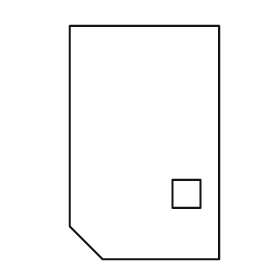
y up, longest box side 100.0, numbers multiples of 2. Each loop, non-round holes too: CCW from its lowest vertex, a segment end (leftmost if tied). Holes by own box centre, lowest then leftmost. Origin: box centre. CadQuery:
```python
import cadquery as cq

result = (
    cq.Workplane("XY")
    .moveTo(-18.0, -50.0)
    .lineTo(32.0, -50.0)
    .lineTo(32.0, 50.0)
    .lineTo(-32.0, 50.0)
    .lineTo(-32.0, -36.0)
    .close()
    .moveTo(12.0, -28.0)
    .lineTo(24.0, -28.0)
    .lineTo(24.0, -16.0)
    .lineTo(12.0, -16.0)
    .close()
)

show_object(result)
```